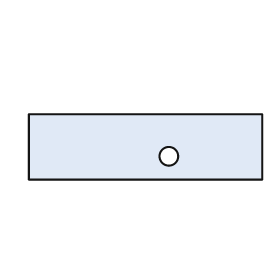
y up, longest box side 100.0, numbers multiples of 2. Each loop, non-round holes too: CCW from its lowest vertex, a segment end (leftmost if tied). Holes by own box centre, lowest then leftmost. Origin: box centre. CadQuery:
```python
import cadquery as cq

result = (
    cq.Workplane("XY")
    .moveTo(-50.0, -14.0)
    .lineTo(50.0, -14.0)
    .lineTo(50.0, 14.0)
    .lineTo(-50.0, 14.0)
    .close()
    .moveTo(10.0, -4.0)
    .circle(4.0)
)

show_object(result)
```